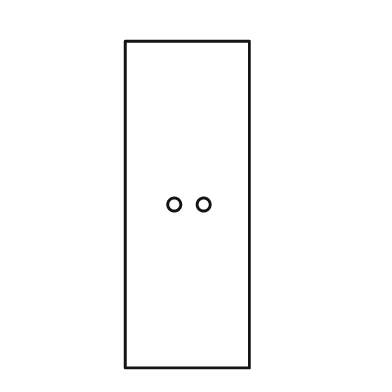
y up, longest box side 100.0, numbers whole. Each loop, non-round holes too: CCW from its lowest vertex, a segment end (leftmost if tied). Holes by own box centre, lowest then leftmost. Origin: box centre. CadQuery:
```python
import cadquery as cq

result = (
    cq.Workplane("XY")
    .moveTo(-19.0, -50.0)
    .lineTo(19.0, -50.0)
    .lineTo(19.0, 50.0)
    .lineTo(-19.0, 50.0)
    .close()
    .moveTo(-4.0, 0.0)
    .circle(2.0)
    .moveTo(5.0, 0.0)
    .circle(2.0)
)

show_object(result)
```